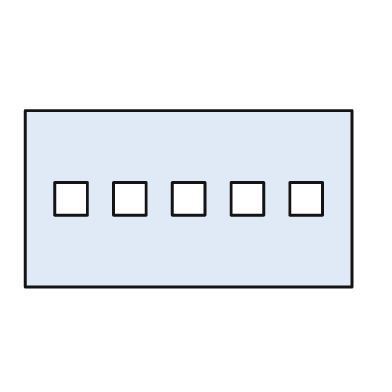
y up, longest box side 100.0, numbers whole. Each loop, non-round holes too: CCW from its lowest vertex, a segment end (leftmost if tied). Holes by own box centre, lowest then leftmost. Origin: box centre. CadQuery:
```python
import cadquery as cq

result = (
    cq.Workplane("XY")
    .moveTo(-50.0, -27.0)
    .lineTo(50.0, -27.0)
    .lineTo(50.0, 27.0)
    .lineTo(-50.0, 27.0)
    .close()
    .moveTo(-41.0, -5.0)
    .lineTo(-31.0, -5.0)
    .lineTo(-31.0, 5.0)
    .lineTo(-41.0, 5.0)
    .close()
    .moveTo(-23.0, -5.0)
    .lineTo(-13.0, -5.0)
    .lineTo(-13.0, 5.0)
    .lineTo(-23.0, 5.0)
    .close()
    .moveTo(-5.0, -5.0)
    .lineTo(5.0, -5.0)
    .lineTo(5.0, 5.0)
    .lineTo(-5.0, 5.0)
    .close()
    .moveTo(13.0, -5.0)
    .lineTo(23.0, -5.0)
    .lineTo(23.0, 5.0)
    .lineTo(13.0, 5.0)
    .close()
    .moveTo(31.0, -5.0)
    .lineTo(41.0, -5.0)
    .lineTo(41.0, 5.0)
    .lineTo(31.0, 5.0)
    .close()
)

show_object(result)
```